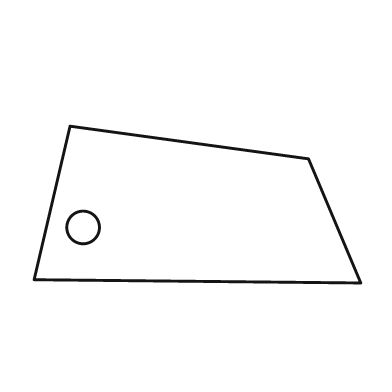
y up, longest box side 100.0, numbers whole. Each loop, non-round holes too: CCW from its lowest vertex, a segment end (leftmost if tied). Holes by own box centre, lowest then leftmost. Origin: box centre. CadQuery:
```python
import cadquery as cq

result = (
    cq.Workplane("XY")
    .moveTo(50.0, -24.0)
    .lineTo(34.0, 14.0)
    .lineTo(-39.0, 24.0)
    .lineTo(-50.0, -23.0)
    .close()
    .moveTo(-35.0, -7.0)
    .circle(5.0)
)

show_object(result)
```